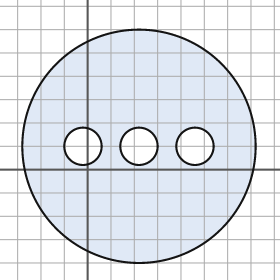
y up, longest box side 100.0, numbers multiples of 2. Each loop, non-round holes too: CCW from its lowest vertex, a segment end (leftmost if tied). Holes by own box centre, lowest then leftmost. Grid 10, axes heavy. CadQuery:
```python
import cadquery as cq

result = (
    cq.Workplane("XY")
    .moveTo(22.0, 10.0)
    .circle(50.0)
    .moveTo(-2.0, 10.0)
    .circle(8.0)
    .moveTo(22.0, 10.0)
    .circle(8.0)
    .moveTo(46.0, 10.0)
    .circle(8.0)
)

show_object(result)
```